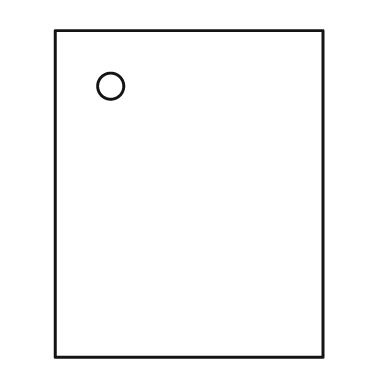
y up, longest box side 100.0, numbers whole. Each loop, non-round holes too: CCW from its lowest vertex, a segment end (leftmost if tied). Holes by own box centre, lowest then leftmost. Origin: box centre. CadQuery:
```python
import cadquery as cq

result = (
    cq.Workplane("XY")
    .moveTo(-41.0, -50.0)
    .lineTo(41.0, -50.0)
    .lineTo(41.0, 50.0)
    .lineTo(-41.0, 50.0)
    .close()
    .moveTo(-24.0, 33.0)
    .circle(4.0)
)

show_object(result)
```